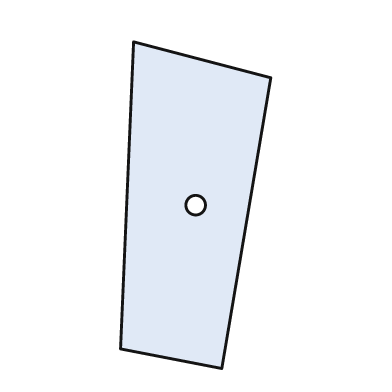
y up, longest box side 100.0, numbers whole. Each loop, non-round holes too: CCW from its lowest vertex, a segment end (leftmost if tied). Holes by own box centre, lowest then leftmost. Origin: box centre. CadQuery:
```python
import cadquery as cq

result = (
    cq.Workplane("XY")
    .moveTo(8.0, -50.0)
    .lineTo(23.0, 39.0)
    .lineTo(-19.0, 50.0)
    .lineTo(-23.0, -44.0)
    .close()
    .moveTo(0.0, 0.0)
    .circle(3.0)
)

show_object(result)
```